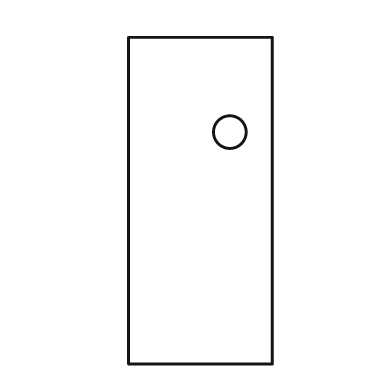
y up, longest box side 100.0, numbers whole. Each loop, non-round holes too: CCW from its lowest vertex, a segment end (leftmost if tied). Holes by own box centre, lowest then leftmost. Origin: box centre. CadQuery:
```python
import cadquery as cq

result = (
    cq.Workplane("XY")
    .moveTo(-22.0, -50.0)
    .lineTo(22.0, -50.0)
    .lineTo(22.0, 50.0)
    .lineTo(-22.0, 50.0)
    .close()
    .moveTo(9.0, 21.0)
    .circle(5.0)
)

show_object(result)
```